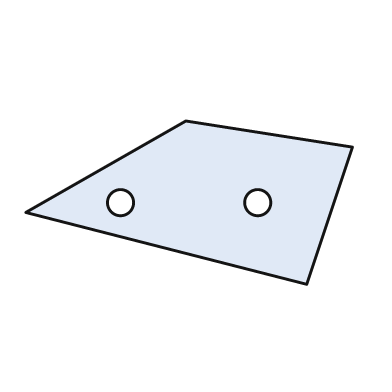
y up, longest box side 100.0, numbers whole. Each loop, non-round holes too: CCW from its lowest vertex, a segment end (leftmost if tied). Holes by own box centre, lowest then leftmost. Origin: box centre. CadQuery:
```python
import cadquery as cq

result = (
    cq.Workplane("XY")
    .moveTo(36.0, -25.0)
    .lineTo(50.0, 17.0)
    .lineTo(-1.0, 25.0)
    .lineTo(-50.0, -3.0)
    .close()
    .moveTo(-21.0, 0.0)
    .circle(4.0)
    .moveTo(21.0, 0.0)
    .circle(4.0)
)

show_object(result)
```